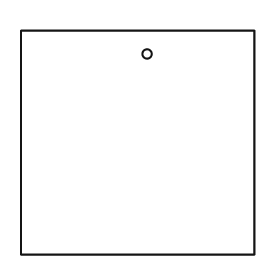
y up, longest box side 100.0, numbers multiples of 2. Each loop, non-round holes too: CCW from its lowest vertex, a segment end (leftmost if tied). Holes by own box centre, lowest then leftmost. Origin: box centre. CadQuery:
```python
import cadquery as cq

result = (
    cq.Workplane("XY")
    .moveTo(-50.0, -48.0)
    .lineTo(50.0, -48.0)
    .lineTo(50.0, 48.0)
    .lineTo(-50.0, 48.0)
    .close()
    .moveTo(4.0, 38.0)
    .circle(2.0)
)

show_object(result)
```